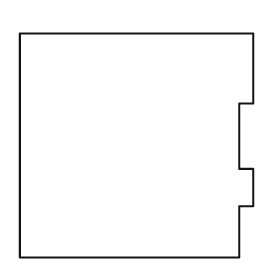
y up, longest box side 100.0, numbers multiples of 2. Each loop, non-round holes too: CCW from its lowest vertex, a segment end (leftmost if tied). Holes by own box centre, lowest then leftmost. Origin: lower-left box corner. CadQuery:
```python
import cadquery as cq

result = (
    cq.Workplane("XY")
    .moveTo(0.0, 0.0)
    .lineTo(94.0, 0.0)
    .lineTo(94.0, 22.0)
    .lineTo(100.0, 22.0)
    .lineTo(100.0, 38.0)
    .lineTo(94.0, 38.0)
    .lineTo(94.0, 66.0)
    .lineTo(100.0, 66.0)
    .lineTo(100.0, 96.0)
    .lineTo(0.0, 96.0)
    .close()
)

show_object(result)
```